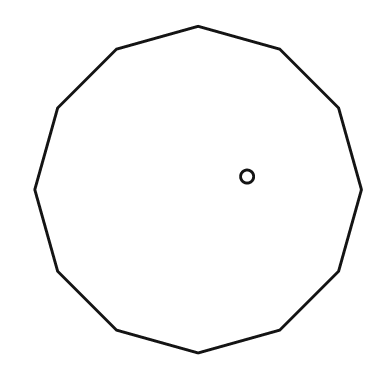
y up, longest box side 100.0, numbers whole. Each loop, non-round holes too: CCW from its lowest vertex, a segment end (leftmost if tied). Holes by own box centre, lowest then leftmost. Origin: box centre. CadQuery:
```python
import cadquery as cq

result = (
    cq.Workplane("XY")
    .moveTo(0.0, -50.0)
    .lineTo(25.0, -43.0)
    .lineTo(43.0, -25.0)
    .lineTo(50.0, 0.0)
    .lineTo(43.0, 25.0)
    .lineTo(25.0, 43.0)
    .lineTo(0.0, 50.0)
    .lineTo(-25.0, 43.0)
    .lineTo(-43.0, 25.0)
    .lineTo(-50.0, 0.0)
    .lineTo(-43.0, -25.0)
    .lineTo(-25.0, -43.0)
    .close()
    .moveTo(15.0, 4.0)
    .circle(2.0)
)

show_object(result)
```